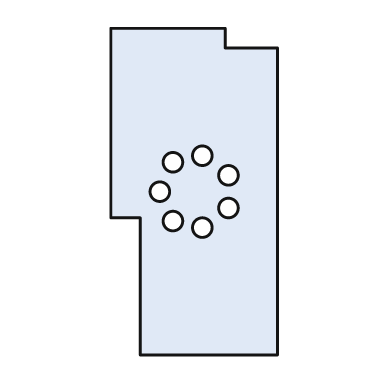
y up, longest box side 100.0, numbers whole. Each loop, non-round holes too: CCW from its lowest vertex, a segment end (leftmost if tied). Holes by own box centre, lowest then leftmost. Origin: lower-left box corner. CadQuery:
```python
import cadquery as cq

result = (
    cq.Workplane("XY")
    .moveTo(9.0, 0.0)
    .lineTo(51.0, 0.0)
    .lineTo(51.0, 94.0)
    .lineTo(35.0, 94.0)
    .lineTo(35.0, 100.0)
    .lineTo(0.0, 100.0)
    .lineTo(0.0, 42.0)
    .lineTo(9.0, 42.0)
    .close()
    .moveTo(28.0, 39.0)
    .circle(3.0)
    .moveTo(19.0, 41.0)
    .circle(3.0)
    .moveTo(36.0, 45.0)
    .circle(3.0)
    .moveTo(15.0, 50.0)
    .circle(3.0)
    .moveTo(36.0, 55.0)
    .circle(3.0)
    .moveTo(19.0, 59.0)
    .circle(3.0)
    .moveTo(28.0, 61.0)
    .circle(3.0)
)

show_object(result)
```